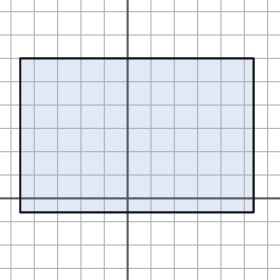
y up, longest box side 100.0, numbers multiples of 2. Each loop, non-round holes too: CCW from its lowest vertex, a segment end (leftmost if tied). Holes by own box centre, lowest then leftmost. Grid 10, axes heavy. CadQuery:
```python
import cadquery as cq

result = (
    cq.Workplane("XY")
    .moveTo(-46.0, -6.0)
    .lineTo(54.0, -6.0)
    .lineTo(54.0, 60.0)
    .lineTo(-46.0, 60.0)
    .close()
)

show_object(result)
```